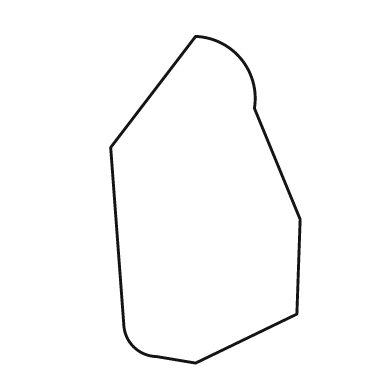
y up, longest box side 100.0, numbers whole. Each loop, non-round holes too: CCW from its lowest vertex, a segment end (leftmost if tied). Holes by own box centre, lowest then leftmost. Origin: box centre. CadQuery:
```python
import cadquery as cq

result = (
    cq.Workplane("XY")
    .moveTo(-3.0, -50.0)
    .lineTo(28.0, -35.0)
    .lineTo(29.0, -6.0)
    .lineTo(15.0, 28.0)
    .threePointArc((11.0, 43.0), (-3.0, 50.0))
    .lineTo(-29.0, 16.0)
    .lineTo(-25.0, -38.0)
    .threePointArc((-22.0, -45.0), (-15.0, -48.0))
    .close()
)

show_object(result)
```